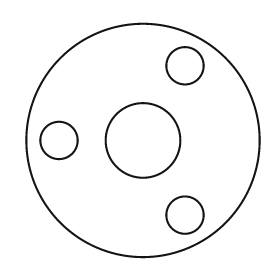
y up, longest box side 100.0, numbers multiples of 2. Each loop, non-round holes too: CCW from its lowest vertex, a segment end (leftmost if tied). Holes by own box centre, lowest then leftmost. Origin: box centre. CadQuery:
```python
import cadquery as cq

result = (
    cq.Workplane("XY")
    .moveTo(0.0, 0.0)
    .circle(50.0)
    .moveTo(18.0, -32.0)
    .circle(8.0)
    .moveTo(-36.0, 0.0)
    .circle(8.0)
    .moveTo(0.0, 0.0)
    .circle(16.0)
    .moveTo(18.0, 32.0)
    .circle(8.0)
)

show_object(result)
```